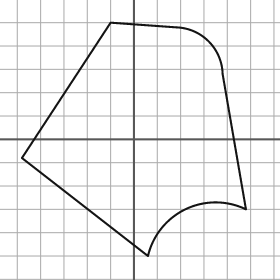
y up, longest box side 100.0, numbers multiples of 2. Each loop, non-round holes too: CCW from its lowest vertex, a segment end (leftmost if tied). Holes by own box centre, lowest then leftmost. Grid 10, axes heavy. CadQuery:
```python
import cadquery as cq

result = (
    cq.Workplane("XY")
    .moveTo(6.0, -50.0)
    .threePointArc((22.0, -30.0), (48.0, -30.0))
    .lineTo(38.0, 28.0)
    .threePointArc((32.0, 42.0), (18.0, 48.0))
    .lineTo(-10.0, 50.0)
    .lineTo(-48.0, -8.0)
    .close()
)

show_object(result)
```